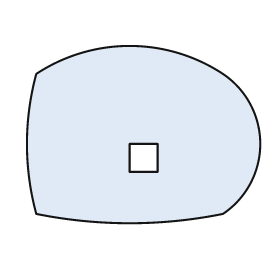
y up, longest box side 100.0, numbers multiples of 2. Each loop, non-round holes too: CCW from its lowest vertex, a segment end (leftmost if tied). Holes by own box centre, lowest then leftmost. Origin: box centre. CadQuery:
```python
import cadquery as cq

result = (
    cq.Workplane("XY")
    .moveTo(-46.0, -34.0)
    .threePointArc((-6.0, -38.0), (34.0, -34.0))
    .threePointArc((50.0, -4.0), (34.0, 26.0))
    .threePointArc((-6.0, 38.0), (-46.0, 26.0))
    .threePointArc((-50.0, -4.0), (-46.0, -34.0))
    .close()
    .moveTo(-6.0, -16.0)
    .lineTo(6.0, -16.0)
    .lineTo(6.0, -4.0)
    .lineTo(-6.0, -4.0)
    .close()
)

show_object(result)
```